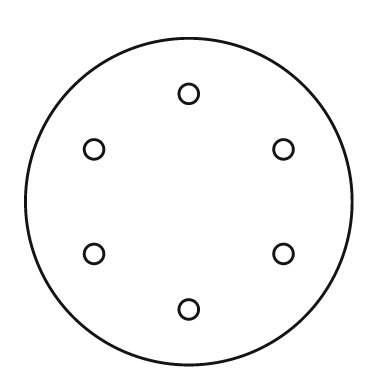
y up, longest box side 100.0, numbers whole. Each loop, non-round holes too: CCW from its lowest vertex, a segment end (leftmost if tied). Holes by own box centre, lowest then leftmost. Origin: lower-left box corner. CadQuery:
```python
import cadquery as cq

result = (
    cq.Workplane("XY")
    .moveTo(50.0, 50.0)
    .circle(50.0)
    .moveTo(50.0, 17.0)
    .circle(3.0)
    .moveTo(21.0, 34.0)
    .circle(3.0)
    .moveTo(79.0, 34.0)
    .circle(3.0)
    .moveTo(21.0, 66.0)
    .circle(3.0)
    .moveTo(79.0, 66.0)
    .circle(3.0)
    .moveTo(50.0, 83.0)
    .circle(3.0)
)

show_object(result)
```